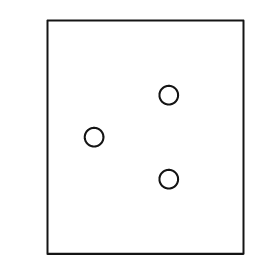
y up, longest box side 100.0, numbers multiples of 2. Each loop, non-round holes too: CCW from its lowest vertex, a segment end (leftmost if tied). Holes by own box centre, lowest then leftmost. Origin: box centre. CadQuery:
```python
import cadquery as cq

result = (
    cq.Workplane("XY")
    .moveTo(-42.0, -50.0)
    .lineTo(42.0, -50.0)
    .lineTo(42.0, 50.0)
    .lineTo(-42.0, 50.0)
    .close()
    .moveTo(10.0, -18.0)
    .circle(4.0)
    .moveTo(-22.0, 0.0)
    .circle(4.0)
    .moveTo(10.0, 18.0)
    .circle(4.0)
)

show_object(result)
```